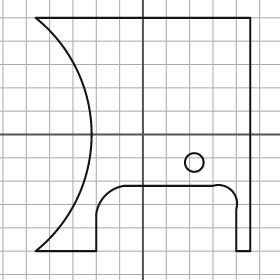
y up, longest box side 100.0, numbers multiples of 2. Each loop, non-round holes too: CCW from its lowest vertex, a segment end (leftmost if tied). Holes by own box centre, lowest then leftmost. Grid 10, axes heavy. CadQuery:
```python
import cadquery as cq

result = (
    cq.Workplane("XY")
    .moveTo(-46.0, -50.0)
    .lineTo(-20.0, -50.0)
    .lineTo(-20.0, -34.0)
    .threePointArc((-16.0, -26.0), (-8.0, -22.0))
    .lineTo(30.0, -22.0)
    .threePointArc((38.0, -24.0), (40.0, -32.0))
    .lineTo(40.0, -50.0)
    .lineTo(46.0, -50.0)
    .lineTo(46.0, 50.0)
    .lineTo(-46.0, 50.0)
    .threePointArc((-22.0, 0.0), (-46.0, -50.0))
    .close()
    .moveTo(22.0, -12.0)
    .circle(4.0)
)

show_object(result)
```